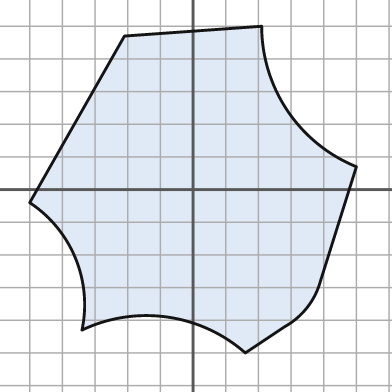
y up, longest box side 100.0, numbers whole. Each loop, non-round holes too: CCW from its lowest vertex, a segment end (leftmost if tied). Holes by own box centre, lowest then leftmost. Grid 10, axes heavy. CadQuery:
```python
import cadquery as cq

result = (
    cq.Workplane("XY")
    .moveTo(16.0, -50.0)
    .lineTo(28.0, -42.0)
    .threePointArc((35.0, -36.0), (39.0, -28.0))
    .lineTo(50.0, 7.0)
    .threePointArc((29.0, 24.0), (21.0, 50.0))
    .lineTo(-21.0, 47.0)
    .lineTo(-50.0, -4.0)
    .threePointArc((-36.0, -21.0), (-34.0, -43.0))
    .threePointArc((-8.0, -39.0), (16.0, -50.0))
    .close()
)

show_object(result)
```